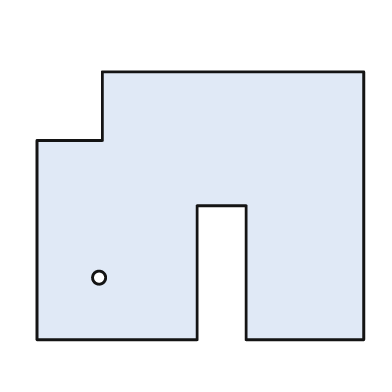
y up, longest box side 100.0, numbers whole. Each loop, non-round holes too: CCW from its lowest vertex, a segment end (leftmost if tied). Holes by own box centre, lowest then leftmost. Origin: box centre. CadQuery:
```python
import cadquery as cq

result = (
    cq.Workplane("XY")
    .moveTo(-50.0, -41.0)
    .lineTo(-1.0, -41.0)
    .lineTo(-1.0, 0.0)
    .lineTo(14.0, 0.0)
    .lineTo(14.0, -41.0)
    .lineTo(50.0, -41.0)
    .lineTo(50.0, 41.0)
    .lineTo(-30.0, 41.0)
    .lineTo(-30.0, 20.0)
    .lineTo(-50.0, 20.0)
    .close()
    .moveTo(-31.0, -22.0)
    .circle(2.0)
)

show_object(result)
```